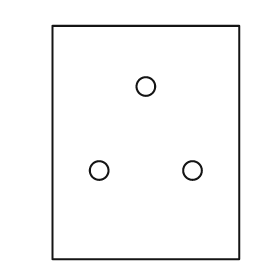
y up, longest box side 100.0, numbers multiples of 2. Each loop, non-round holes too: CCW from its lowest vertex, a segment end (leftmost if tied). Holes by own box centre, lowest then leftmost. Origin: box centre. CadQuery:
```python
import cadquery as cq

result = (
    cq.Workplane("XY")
    .moveTo(-40.0, -50.0)
    .lineTo(40.0, -50.0)
    .lineTo(40.0, 50.0)
    .lineTo(-40.0, 50.0)
    .close()
    .moveTo(-20.0, -12.0)
    .circle(4.0)
    .moveTo(20.0, -12.0)
    .circle(4.0)
    .moveTo(0.0, 24.0)
    .circle(4.0)
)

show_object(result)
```